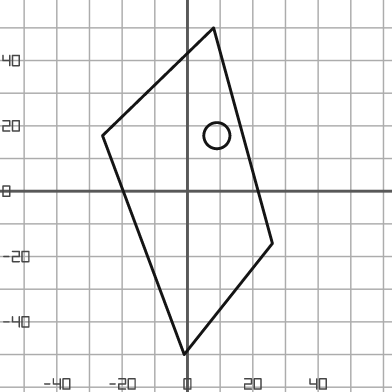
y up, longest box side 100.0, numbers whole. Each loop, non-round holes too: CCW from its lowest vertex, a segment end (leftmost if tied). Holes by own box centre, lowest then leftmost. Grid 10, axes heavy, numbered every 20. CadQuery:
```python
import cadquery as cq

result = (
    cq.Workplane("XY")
    .moveTo(-1.0, -50.0)
    .lineTo(26.0, -16.0)
    .lineTo(8.0, 50.0)
    .lineTo(-26.0, 17.0)
    .close()
    .moveTo(9.0, 17.0)
    .circle(4.0)
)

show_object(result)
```